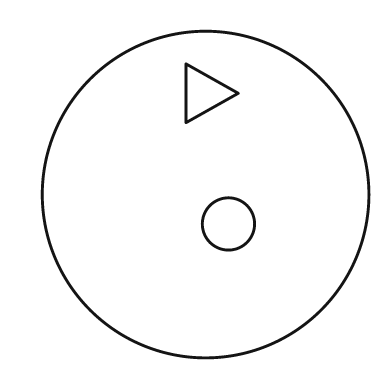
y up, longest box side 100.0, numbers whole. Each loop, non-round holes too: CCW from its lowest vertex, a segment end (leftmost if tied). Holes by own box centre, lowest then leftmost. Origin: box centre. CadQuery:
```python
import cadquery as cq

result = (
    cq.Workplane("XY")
    .moveTo(0.0, 0.0)
    .circle(50.0)
    .moveTo(7.0, -9.0)
    .circle(8.0)
    .moveTo(-6.0, 22.0)
    .lineTo(10.0, 31.0)
    .lineTo(-6.0, 40.0)
    .close()
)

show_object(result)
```